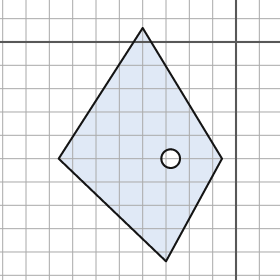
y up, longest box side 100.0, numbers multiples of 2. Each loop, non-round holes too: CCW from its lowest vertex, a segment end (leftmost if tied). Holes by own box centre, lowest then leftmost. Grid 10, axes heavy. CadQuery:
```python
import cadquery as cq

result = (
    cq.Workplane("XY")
    .moveTo(-30.0, -94.0)
    .lineTo(-6.0, -50.0)
    .lineTo(-40.0, 6.0)
    .lineTo(-76.0, -50.0)
    .close()
    .moveTo(-28.0, -50.0)
    .circle(4.0)
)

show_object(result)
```